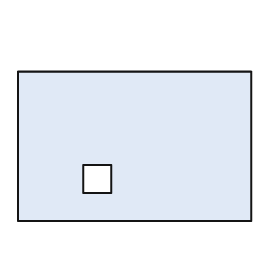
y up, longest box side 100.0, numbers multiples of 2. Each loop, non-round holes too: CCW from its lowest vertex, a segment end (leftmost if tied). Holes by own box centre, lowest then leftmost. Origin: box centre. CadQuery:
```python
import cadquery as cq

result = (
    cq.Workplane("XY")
    .moveTo(-50.0, -32.0)
    .lineTo(50.0, -32.0)
    .lineTo(50.0, 32.0)
    .lineTo(-50.0, 32.0)
    .close()
    .moveTo(-22.0, -20.0)
    .lineTo(-10.0, -20.0)
    .lineTo(-10.0, -8.0)
    .lineTo(-22.0, -8.0)
    .close()
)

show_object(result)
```